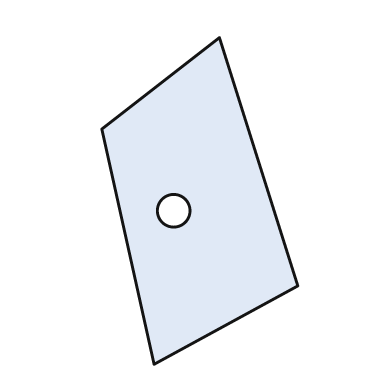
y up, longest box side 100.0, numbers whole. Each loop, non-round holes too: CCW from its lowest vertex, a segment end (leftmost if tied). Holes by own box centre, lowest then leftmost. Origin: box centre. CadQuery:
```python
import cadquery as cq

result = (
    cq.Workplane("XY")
    .moveTo(-14.0, -50.0)
    .lineTo(30.0, -26.0)
    .lineTo(6.0, 50.0)
    .lineTo(-30.0, 22.0)
    .close()
    .moveTo(-8.0, -3.0)
    .circle(5.0)
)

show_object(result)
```